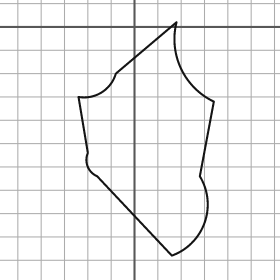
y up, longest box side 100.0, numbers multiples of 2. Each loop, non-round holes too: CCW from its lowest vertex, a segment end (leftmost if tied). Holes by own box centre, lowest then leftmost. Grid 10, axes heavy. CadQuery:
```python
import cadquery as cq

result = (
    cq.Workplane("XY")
    .moveTo(16.0, -98.0)
    .threePointArc((30.0, -84.0), (28.0, -64.0))
    .lineTo(34.0, -32.0)
    .threePointArc((20.0, -18.0), (18.0, 2.0))
    .lineTo(-8.0, -20.0)
    .threePointArc((-14.0, -28.0), (-24.0, -30.0))
    .lineTo(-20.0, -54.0)
    .threePointArc((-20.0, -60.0), (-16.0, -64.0))
    .close()
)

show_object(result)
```